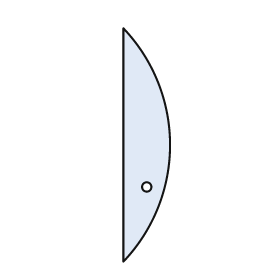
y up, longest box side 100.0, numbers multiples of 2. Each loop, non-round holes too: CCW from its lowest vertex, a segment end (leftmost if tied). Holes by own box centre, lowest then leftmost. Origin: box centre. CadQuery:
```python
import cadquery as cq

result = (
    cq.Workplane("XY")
    .moveTo(-10.0, -50.0)
    .threePointArc((10.0, 0.0), (-10.0, 50.0))
    .close()
    .moveTo(0.0, -18.0)
    .circle(2.0)
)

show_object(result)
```